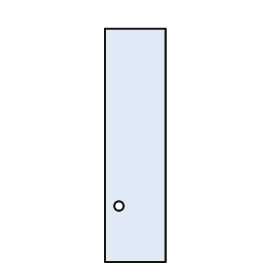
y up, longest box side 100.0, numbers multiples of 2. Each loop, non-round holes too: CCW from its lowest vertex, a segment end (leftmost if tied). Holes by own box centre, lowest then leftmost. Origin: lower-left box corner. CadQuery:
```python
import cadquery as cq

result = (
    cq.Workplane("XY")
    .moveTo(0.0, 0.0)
    .lineTo(26.0, 0.0)
    .lineTo(26.0, 100.0)
    .lineTo(0.0, 100.0)
    .close()
    .moveTo(6.0, 24.0)
    .circle(2.0)
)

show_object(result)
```